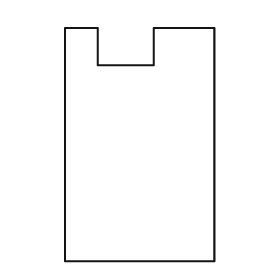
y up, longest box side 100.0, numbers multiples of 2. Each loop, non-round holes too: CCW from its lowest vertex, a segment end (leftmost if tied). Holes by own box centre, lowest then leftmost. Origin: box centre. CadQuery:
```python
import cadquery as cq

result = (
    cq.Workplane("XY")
    .moveTo(-32.0, -50.0)
    .lineTo(32.0, -50.0)
    .lineTo(32.0, 50.0)
    .lineTo(6.0, 50.0)
    .lineTo(6.0, 34.0)
    .lineTo(-18.0, 34.0)
    .lineTo(-18.0, 50.0)
    .lineTo(-32.0, 50.0)
    .close()
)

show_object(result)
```